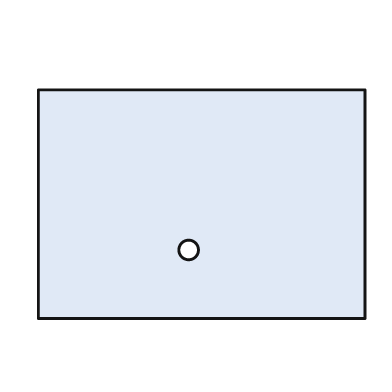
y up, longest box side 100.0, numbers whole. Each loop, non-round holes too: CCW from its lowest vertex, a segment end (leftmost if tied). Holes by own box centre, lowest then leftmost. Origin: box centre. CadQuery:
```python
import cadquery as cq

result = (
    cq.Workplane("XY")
    .moveTo(-50.0, -35.0)
    .lineTo(50.0, -35.0)
    .lineTo(50.0, 35.0)
    .lineTo(-50.0, 35.0)
    .close()
    .moveTo(-4.0, -14.0)
    .circle(3.0)
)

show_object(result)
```